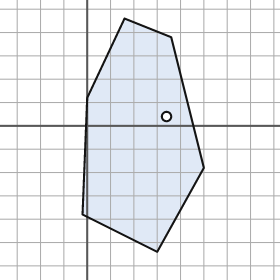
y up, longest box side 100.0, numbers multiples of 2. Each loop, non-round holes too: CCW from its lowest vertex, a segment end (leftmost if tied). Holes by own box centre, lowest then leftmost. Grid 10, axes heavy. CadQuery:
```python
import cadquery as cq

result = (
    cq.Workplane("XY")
    .moveTo(30.0, -54.0)
    .lineTo(50.0, -18.0)
    .lineTo(36.0, 38.0)
    .lineTo(16.0, 46.0)
    .lineTo(0.0, 12.0)
    .lineTo(-2.0, -38.0)
    .close()
    .moveTo(34.0, 4.0)
    .circle(2.0)
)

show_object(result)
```